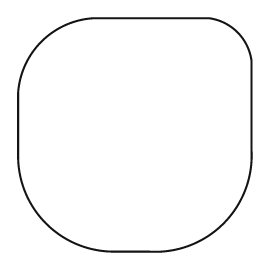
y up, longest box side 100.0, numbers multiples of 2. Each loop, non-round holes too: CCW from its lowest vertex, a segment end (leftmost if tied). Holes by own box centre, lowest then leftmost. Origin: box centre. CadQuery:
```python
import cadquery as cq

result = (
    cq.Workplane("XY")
    .moveTo(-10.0, -50.0)
    .lineTo(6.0, -50.0)
    .threePointArc((38.0, -38.0), (50.0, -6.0))
    .lineTo(50.0, 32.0)
    .threePointArc((44.0, 44.0), (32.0, 50.0))
    .lineTo(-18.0, 50.0)
    .threePointArc((-40.0, 40.0), (-50.0, 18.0))
    .lineTo(-50.0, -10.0)
    .threePointArc((-38.0, -38.0), (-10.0, -50.0))
    .close()
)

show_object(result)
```